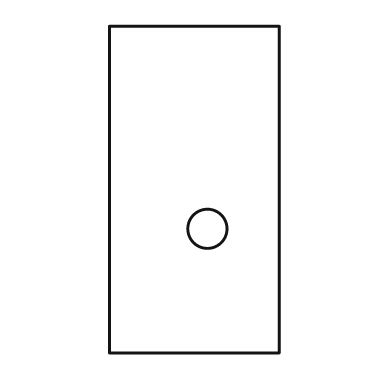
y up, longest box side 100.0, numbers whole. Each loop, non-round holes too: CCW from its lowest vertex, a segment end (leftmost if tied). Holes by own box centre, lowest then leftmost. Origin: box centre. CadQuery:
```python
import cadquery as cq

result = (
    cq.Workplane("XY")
    .moveTo(-26.0, -50.0)
    .lineTo(26.0, -50.0)
    .lineTo(26.0, 50.0)
    .lineTo(-26.0, 50.0)
    .close()
    .moveTo(4.0, -12.0)
    .circle(6.0)
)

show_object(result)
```